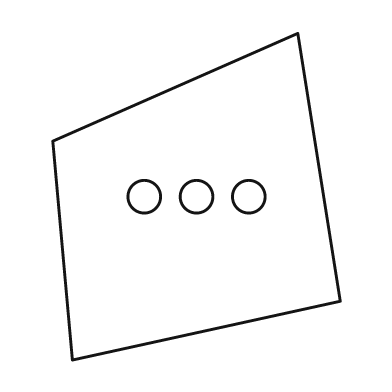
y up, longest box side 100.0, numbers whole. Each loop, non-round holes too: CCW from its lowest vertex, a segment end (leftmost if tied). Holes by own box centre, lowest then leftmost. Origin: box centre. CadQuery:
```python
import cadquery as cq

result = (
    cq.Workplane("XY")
    .moveTo(-38.0, -50.0)
    .lineTo(44.0, -32.0)
    .lineTo(31.0, 50.0)
    .lineTo(-44.0, 17.0)
    .close()
    .moveTo(-16.0, 0.0)
    .circle(5.0)
    .moveTo(0.0, 0.0)
    .circle(5.0)
    .moveTo(16.0, 0.0)
    .circle(5.0)
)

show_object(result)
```